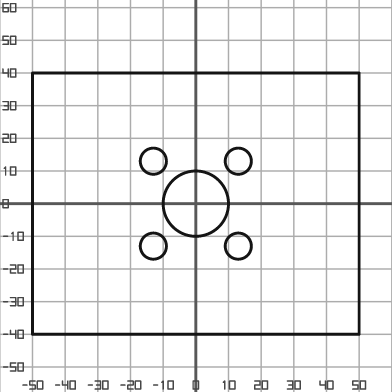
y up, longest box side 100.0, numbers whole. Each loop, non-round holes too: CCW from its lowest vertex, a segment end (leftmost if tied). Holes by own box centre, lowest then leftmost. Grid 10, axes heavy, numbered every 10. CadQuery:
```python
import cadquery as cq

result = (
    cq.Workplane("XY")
    .moveTo(-50.0, -40.0)
    .lineTo(50.0, -40.0)
    .lineTo(50.0, 40.0)
    .lineTo(-50.0, 40.0)
    .close()
    .moveTo(-13.0, -13.0)
    .circle(4.0)
    .moveTo(13.0, -13.0)
    .circle(4.0)
    .moveTo(0.0, 0.0)
    .circle(10.0)
    .moveTo(-13.0, 13.0)
    .circle(4.0)
    .moveTo(13.0, 13.0)
    .circle(4.0)
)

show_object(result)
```